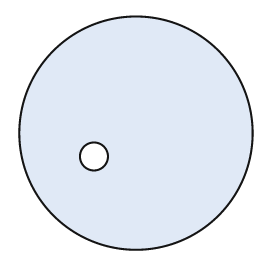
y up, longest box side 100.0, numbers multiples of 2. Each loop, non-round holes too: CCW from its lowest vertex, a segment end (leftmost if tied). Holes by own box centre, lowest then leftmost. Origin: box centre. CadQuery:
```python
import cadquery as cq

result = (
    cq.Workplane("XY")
    .moveTo(0.0, 0.0)
    .circle(50.0)
    .moveTo(-18.0, -10.0)
    .circle(6.0)
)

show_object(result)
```